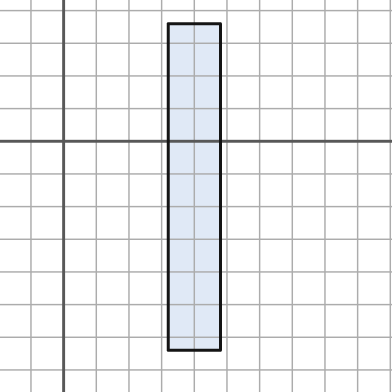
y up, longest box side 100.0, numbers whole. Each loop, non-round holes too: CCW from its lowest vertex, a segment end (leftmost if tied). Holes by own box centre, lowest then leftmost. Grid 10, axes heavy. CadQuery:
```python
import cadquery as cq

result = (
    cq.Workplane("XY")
    .moveTo(32.0, -64.0)
    .lineTo(48.0, -64.0)
    .lineTo(48.0, 36.0)
    .lineTo(32.0, 36.0)
    .close()
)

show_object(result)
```